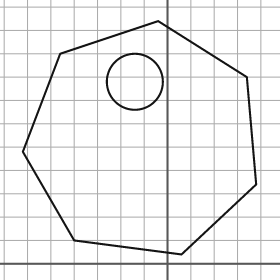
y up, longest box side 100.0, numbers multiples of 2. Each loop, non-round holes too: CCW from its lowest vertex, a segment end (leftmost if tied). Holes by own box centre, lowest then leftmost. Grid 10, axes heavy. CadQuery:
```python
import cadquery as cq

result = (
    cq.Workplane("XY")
    .moveTo(6.0, 4.0)
    .lineTo(38.0, 34.0)
    .lineTo(34.0, 80.0)
    .lineTo(-4.0, 104.0)
    .lineTo(-46.0, 90.0)
    .lineTo(-62.0, 48.0)
    .lineTo(-40.0, 10.0)
    .close()
    .moveTo(-14.0, 78.0)
    .circle(12.0)
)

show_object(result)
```